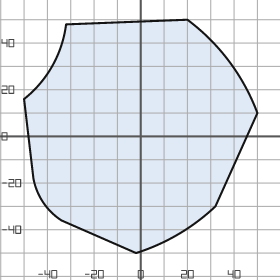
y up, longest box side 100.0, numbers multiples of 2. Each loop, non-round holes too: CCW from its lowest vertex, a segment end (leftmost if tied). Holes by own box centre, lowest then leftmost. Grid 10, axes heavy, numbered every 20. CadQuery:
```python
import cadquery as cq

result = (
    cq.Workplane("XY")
    .moveTo(-2.0, -50.0)
    .threePointArc((16.0, -42.0), (32.0, -30.0))
    .lineTo(50.0, 10.0)
    .threePointArc((38.0, 32.0), (20.0, 50.0))
    .lineTo(-32.0, 48.0)
    .threePointArc((-38.0, 30.0), (-50.0, 16.0))
    .lineTo(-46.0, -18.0)
    .threePointArc((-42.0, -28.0), (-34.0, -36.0))
    .close()
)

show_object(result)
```